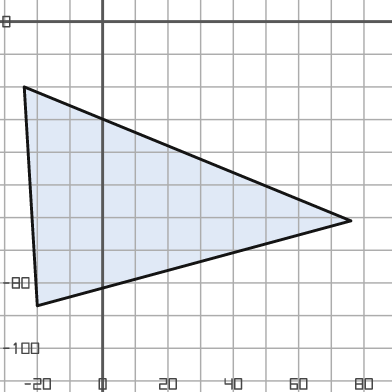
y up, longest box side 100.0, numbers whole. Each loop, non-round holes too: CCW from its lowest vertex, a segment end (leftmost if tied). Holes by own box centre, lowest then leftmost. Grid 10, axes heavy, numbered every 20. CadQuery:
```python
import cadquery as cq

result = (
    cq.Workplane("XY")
    .moveTo(-20.0, -87.0)
    .lineTo(76.0, -61.0)
    .lineTo(-24.0, -20.0)
    .close()
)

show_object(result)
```